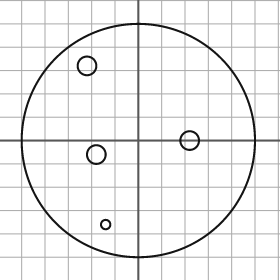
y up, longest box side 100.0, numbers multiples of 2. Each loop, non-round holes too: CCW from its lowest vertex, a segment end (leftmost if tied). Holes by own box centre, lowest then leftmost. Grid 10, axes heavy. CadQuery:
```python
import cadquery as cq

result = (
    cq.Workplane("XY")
    .moveTo(0.0, 0.0)
    .circle(50.0)
    .moveTo(-14.0, -36.0)
    .circle(2.0)
    .moveTo(-18.0, -6.0)
    .circle(4.0)
    .moveTo(22.0, 0.0)
    .circle(4.0)
    .moveTo(-22.0, 32.0)
    .circle(4.0)
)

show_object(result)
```